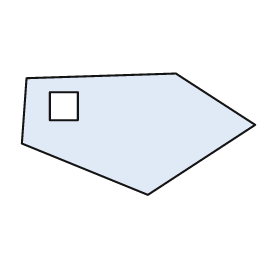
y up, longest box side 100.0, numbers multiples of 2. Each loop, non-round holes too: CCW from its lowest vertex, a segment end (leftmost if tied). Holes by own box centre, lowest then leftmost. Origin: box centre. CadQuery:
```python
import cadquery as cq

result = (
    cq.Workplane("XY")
    .moveTo(4.0, -26.0)
    .lineTo(50.0, 4.0)
    .lineTo(16.0, 26.0)
    .lineTo(-48.0, 24.0)
    .lineTo(-50.0, -4.0)
    .close()
    .moveTo(-38.0, 6.0)
    .lineTo(-26.0, 6.0)
    .lineTo(-26.0, 18.0)
    .lineTo(-38.0, 18.0)
    .close()
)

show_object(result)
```